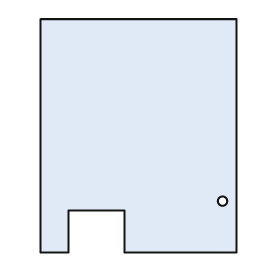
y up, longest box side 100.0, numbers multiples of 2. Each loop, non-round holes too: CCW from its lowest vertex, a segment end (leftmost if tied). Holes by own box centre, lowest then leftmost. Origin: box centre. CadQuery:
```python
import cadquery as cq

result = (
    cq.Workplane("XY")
    .moveTo(-42.0, -50.0)
    .lineTo(-30.0, -50.0)
    .lineTo(-30.0, -32.0)
    .lineTo(-6.0, -32.0)
    .lineTo(-6.0, -50.0)
    .lineTo(42.0, -50.0)
    .lineTo(42.0, 50.0)
    .lineTo(-42.0, 50.0)
    .close()
    .moveTo(36.0, -28.0)
    .circle(2.0)
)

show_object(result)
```